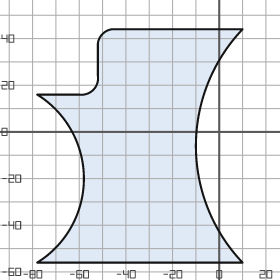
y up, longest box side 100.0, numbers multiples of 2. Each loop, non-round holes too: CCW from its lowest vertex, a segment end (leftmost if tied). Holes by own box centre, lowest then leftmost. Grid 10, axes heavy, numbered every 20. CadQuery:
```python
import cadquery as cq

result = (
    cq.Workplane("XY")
    .moveTo(-78.0, -56.0)
    .lineTo(10.0, -56.0)
    .threePointArc((-10.0, -6.0), (10.0, 44.0))
    .lineTo(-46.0, 44.0)
    .threePointArc((-50.0, 42.0), (-52.0, 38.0))
    .lineTo(-52.0, 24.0)
    .threePointArc((-54.0, 18.0), (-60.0, 16.0))
    .lineTo(-78.0, 16.0)
    .threePointArc((-58.0, -20.0), (-78.0, -56.0))
    .close()
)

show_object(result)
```